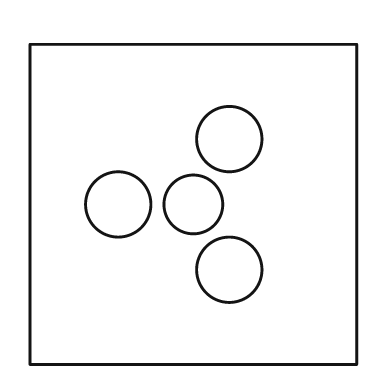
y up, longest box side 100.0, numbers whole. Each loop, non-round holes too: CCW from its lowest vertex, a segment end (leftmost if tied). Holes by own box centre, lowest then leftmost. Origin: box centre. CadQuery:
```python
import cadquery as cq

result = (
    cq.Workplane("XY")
    .moveTo(-50.0, -49.0)
    .lineTo(50.0, -49.0)
    .lineTo(50.0, 49.0)
    .lineTo(-50.0, 49.0)
    .close()
    .moveTo(11.0, -20.0)
    .circle(10.0)
    .moveTo(-23.0, 0.0)
    .circle(10.0)
    .moveTo(0.0, 0.0)
    .circle(9.0)
    .moveTo(11.0, 20.0)
    .circle(10.0)
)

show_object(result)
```